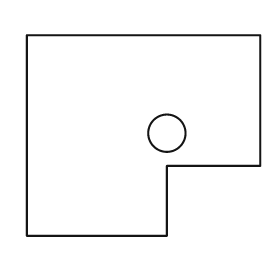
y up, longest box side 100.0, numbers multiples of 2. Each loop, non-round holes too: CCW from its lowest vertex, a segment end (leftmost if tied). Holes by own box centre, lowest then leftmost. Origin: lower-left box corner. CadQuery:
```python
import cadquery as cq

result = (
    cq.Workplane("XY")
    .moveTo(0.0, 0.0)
    .lineTo(60.0, 0.0)
    .lineTo(60.0, 30.0)
    .lineTo(100.0, 30.0)
    .lineTo(100.0, 86.0)
    .lineTo(0.0, 86.0)
    .close()
    .moveTo(60.0, 44.0)
    .circle(8.0)
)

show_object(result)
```